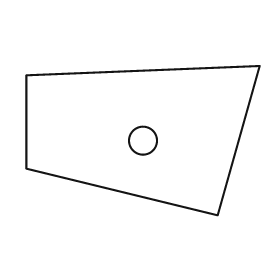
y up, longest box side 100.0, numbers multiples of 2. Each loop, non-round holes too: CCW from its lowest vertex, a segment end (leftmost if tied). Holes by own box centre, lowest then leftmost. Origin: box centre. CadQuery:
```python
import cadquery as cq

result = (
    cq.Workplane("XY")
    .moveTo(32.0, -32.0)
    .lineTo(50.0, 32.0)
    .lineTo(-50.0, 28.0)
    .lineTo(-50.0, -12.0)
    .close()
    .moveTo(0.0, 0.0)
    .circle(6.0)
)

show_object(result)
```